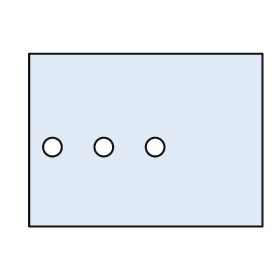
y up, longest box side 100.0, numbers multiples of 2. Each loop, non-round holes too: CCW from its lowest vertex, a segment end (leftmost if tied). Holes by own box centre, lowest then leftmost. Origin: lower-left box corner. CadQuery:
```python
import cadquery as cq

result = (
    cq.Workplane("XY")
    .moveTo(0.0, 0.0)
    .lineTo(100.0, 0.0)
    .lineTo(100.0, 74.0)
    .lineTo(0.0, 74.0)
    .close()
    .moveTo(10.0, 34.0)
    .circle(4.0)
    .moveTo(32.0, 34.0)
    .circle(4.0)
    .moveTo(54.0, 34.0)
    .circle(4.0)
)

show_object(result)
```